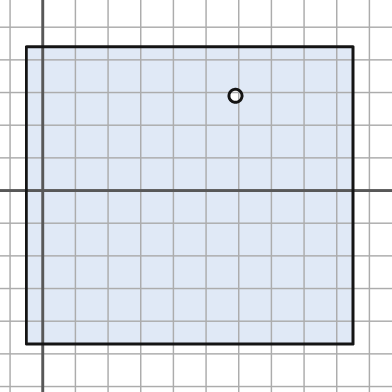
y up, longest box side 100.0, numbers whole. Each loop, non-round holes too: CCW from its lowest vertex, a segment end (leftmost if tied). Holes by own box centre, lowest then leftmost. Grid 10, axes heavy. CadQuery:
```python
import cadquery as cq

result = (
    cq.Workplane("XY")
    .moveTo(-5.0, -47.0)
    .lineTo(95.0, -47.0)
    .lineTo(95.0, 44.0)
    .lineTo(-5.0, 44.0)
    .close()
    .moveTo(59.0, 29.0)
    .circle(2.0)
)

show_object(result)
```